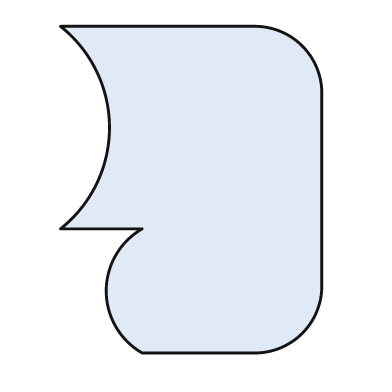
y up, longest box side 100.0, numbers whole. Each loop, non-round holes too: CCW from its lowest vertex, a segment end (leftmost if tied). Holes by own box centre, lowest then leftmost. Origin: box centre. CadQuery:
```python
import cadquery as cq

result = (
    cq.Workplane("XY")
    .moveTo(-15.0, -50.0)
    .lineTo(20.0, -50.0)
    .threePointArc((34.0, -44.0), (40.0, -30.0))
    .lineTo(40.0, 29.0)
    .threePointArc((34.0, 44.0), (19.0, 50.0))
    .lineTo(-40.0, 50.0)
    .threePointArc((-25.0, 19.0), (-40.0, -12.0))
    .lineTo(-15.0, -12.0)
    .threePointArc((-26.0, -31.0), (-15.0, -50.0))
    .close()
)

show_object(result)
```